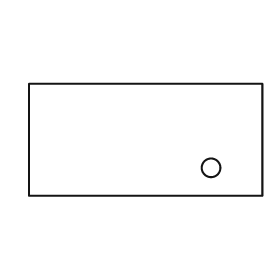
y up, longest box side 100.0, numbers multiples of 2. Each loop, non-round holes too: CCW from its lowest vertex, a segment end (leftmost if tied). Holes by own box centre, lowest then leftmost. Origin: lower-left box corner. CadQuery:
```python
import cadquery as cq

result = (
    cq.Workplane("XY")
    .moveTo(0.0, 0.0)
    .lineTo(100.0, 0.0)
    .lineTo(100.0, 48.0)
    .lineTo(0.0, 48.0)
    .close()
    .moveTo(78.0, 12.0)
    .circle(4.0)
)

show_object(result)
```